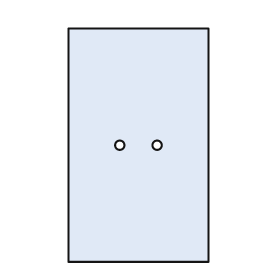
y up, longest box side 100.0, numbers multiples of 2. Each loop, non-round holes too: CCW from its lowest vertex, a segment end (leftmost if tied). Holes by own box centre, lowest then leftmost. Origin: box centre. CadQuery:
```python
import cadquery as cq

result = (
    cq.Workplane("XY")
    .moveTo(-30.0, -50.0)
    .lineTo(30.0, -50.0)
    .lineTo(30.0, 50.0)
    .lineTo(-30.0, 50.0)
    .close()
    .moveTo(-8.0, 0.0)
    .circle(2.0)
    .moveTo(8.0, 0.0)
    .circle(2.0)
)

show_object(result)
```